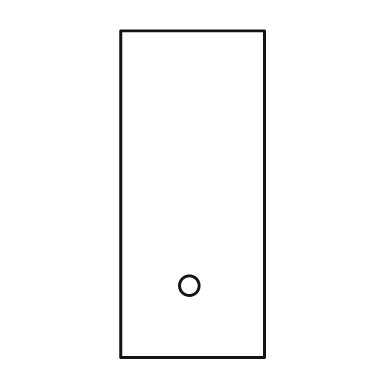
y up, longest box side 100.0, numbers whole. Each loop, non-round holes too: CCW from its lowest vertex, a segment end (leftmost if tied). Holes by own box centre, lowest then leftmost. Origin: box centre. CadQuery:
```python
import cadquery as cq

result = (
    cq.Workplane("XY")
    .moveTo(-22.0, -50.0)
    .lineTo(22.0, -50.0)
    .lineTo(22.0, 50.0)
    .lineTo(-22.0, 50.0)
    .close()
    .moveTo(-1.0, -28.0)
    .circle(3.0)
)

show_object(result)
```